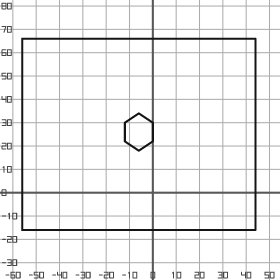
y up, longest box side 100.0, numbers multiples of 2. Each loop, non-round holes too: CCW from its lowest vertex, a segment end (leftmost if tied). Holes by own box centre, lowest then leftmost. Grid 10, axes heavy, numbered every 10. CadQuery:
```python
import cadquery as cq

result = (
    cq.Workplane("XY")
    .moveTo(-56.0, -16.0)
    .lineTo(44.0, -16.0)
    .lineTo(44.0, 66.0)
    .lineTo(-56.0, 66.0)
    .close()
    .moveTo(-6.0, 18.0)
    .lineTo(0.0, 22.0)
    .lineTo(0.0, 30.0)
    .lineTo(-6.0, 34.0)
    .lineTo(-12.0, 30.0)
    .lineTo(-12.0, 22.0)
    .close()
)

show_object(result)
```